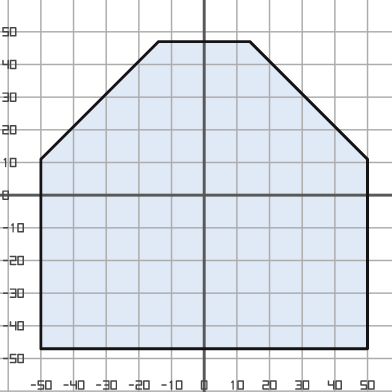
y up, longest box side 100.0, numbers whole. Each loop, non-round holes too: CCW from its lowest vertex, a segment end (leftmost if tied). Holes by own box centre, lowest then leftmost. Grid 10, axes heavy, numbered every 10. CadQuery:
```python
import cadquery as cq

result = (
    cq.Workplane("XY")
    .moveTo(-50.0, -47.0)
    .lineTo(50.0, -47.0)
    .lineTo(50.0, 11.0)
    .lineTo(14.0, 47.0)
    .lineTo(-14.0, 47.0)
    .lineTo(-50.0, 11.0)
    .close()
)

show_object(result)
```